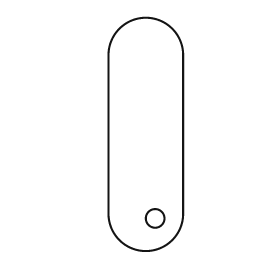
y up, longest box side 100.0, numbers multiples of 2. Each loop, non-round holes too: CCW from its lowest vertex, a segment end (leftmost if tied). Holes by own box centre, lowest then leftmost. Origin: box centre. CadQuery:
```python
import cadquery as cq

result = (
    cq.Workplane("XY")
    .moveTo(-16.0, -34.0)
    .threePointArc((0.0, -50.0), (16.0, -34.0))
    .lineTo(16.0, 34.0)
    .threePointArc((0.0, 50.0), (-16.0, 34.0))
    .close()
    .moveTo(4.0, -36.0)
    .circle(4.0)
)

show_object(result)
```